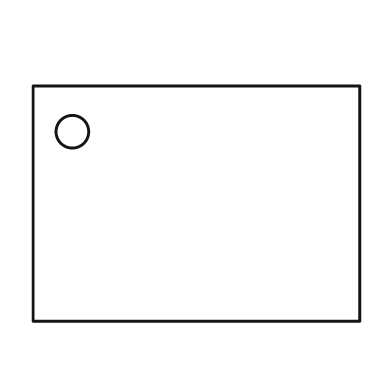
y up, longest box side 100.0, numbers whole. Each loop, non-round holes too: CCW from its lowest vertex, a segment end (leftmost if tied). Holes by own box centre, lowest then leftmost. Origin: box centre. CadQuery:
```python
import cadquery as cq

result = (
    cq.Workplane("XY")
    .moveTo(-50.0, -36.0)
    .lineTo(50.0, -36.0)
    .lineTo(50.0, 36.0)
    .lineTo(-50.0, 36.0)
    .close()
    .moveTo(-38.0, 22.0)
    .circle(5.0)
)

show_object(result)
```